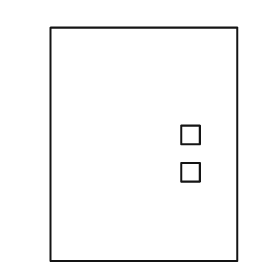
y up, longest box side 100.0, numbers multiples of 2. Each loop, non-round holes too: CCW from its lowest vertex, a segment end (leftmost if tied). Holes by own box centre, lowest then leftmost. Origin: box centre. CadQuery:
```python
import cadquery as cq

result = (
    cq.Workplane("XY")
    .moveTo(-40.0, -50.0)
    .lineTo(40.0, -50.0)
    .lineTo(40.0, 50.0)
    .lineTo(-40.0, 50.0)
    .close()
    .moveTo(16.0, -16.0)
    .lineTo(24.0, -16.0)
    .lineTo(24.0, -8.0)
    .lineTo(16.0, -8.0)
    .close()
    .moveTo(16.0, 0.0)
    .lineTo(24.0, 0.0)
    .lineTo(24.0, 8.0)
    .lineTo(16.0, 8.0)
    .close()
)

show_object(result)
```